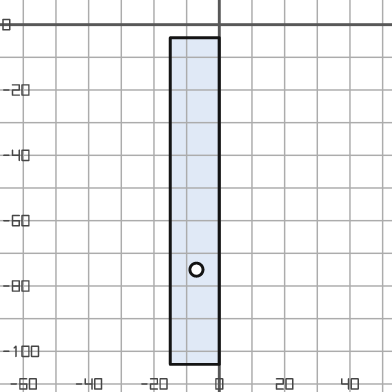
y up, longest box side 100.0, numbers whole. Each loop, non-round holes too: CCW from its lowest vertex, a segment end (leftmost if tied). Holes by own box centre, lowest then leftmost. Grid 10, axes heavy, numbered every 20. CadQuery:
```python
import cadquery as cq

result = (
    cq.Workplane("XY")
    .moveTo(-15.0, -104.0)
    .lineTo(0.0, -104.0)
    .lineTo(0.0, -4.0)
    .lineTo(-15.0, -4.0)
    .close()
    .moveTo(-7.0, -75.0)
    .circle(2.0)
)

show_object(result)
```